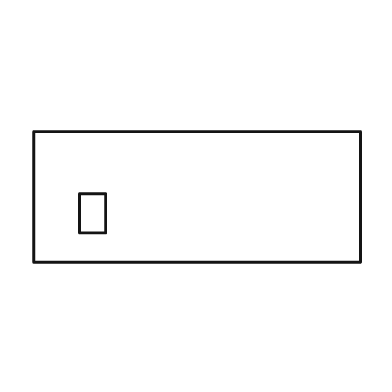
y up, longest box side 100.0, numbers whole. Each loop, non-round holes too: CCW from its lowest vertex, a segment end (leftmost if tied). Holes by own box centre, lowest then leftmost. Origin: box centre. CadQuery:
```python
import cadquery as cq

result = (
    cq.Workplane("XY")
    .moveTo(-50.0, -20.0)
    .lineTo(50.0, -20.0)
    .lineTo(50.0, 20.0)
    .lineTo(-50.0, 20.0)
    .close()
    .moveTo(-36.0, -11.0)
    .lineTo(-28.0, -11.0)
    .lineTo(-28.0, 1.0)
    .lineTo(-36.0, 1.0)
    .close()
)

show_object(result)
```